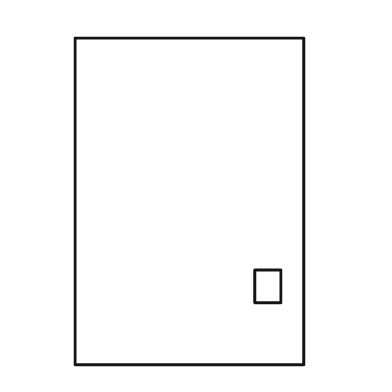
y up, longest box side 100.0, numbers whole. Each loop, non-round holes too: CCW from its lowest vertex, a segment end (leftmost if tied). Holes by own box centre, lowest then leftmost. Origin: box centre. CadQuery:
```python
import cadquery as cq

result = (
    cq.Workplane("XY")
    .moveTo(-35.0, -50.0)
    .lineTo(35.0, -50.0)
    .lineTo(35.0, 50.0)
    .lineTo(-35.0, 50.0)
    .close()
    .moveTo(20.0, -31.0)
    .lineTo(28.0, -31.0)
    .lineTo(28.0, -21.0)
    .lineTo(20.0, -21.0)
    .close()
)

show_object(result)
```